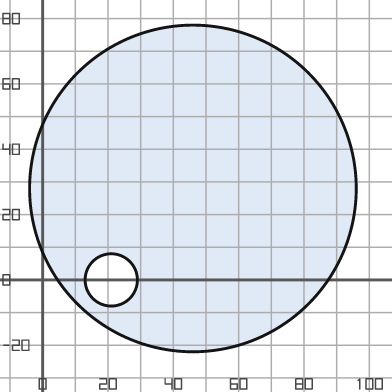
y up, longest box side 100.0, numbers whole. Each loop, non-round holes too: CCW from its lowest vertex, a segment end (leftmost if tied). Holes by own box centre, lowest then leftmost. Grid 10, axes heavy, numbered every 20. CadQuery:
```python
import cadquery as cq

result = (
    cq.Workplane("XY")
    .moveTo(46.0, 28.0)
    .circle(50.0)
    .moveTo(21.0, 0.0)
    .circle(8.0)
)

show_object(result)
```